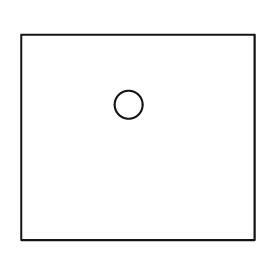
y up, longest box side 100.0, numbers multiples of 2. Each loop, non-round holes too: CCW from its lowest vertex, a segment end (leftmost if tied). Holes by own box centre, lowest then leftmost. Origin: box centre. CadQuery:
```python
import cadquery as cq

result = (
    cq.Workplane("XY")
    .moveTo(-50.0, -44.0)
    .lineTo(50.0, -44.0)
    .lineTo(50.0, 44.0)
    .lineTo(-50.0, 44.0)
    .close()
    .moveTo(-4.0, 14.0)
    .circle(6.0)
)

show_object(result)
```